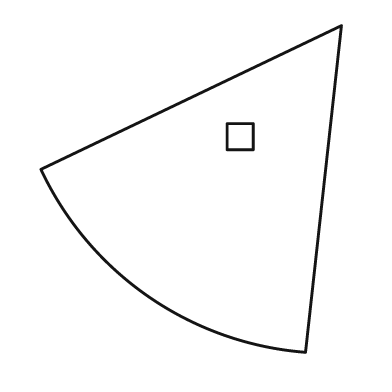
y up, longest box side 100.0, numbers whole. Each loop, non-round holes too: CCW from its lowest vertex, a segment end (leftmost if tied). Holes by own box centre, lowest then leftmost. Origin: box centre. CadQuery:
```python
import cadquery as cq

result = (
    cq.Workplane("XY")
    .moveTo(35.0, -50.0)
    .lineTo(46.0, 50.0)
    .lineTo(-46.0, 6.0)
    .threePointArc((-13.0, -33.0), (35.0, -50.0))
    .close()
    .moveTo(11.0, 12.0)
    .lineTo(19.0, 12.0)
    .lineTo(19.0, 20.0)
    .lineTo(11.0, 20.0)
    .close()
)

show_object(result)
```